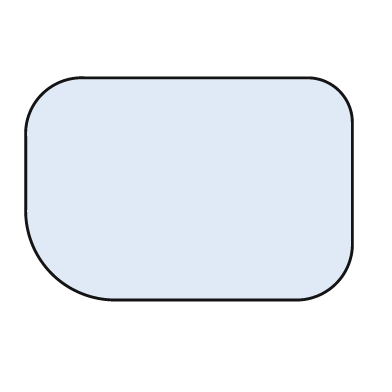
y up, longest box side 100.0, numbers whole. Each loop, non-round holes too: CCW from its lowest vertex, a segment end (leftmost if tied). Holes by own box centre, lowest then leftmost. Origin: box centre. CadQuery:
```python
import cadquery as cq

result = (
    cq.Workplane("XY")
    .moveTo(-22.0, -34.0)
    .lineTo(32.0, -34.0)
    .threePointArc((45.0, -29.0), (50.0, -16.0))
    .lineTo(50.0, 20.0)
    .threePointArc((46.0, 30.0), (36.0, 34.0))
    .lineTo(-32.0, 34.0)
    .threePointArc((-45.0, 29.0), (-50.0, 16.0))
    .lineTo(-50.0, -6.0)
    .threePointArc((-42.0, -26.0), (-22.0, -34.0))
    .close()
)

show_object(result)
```